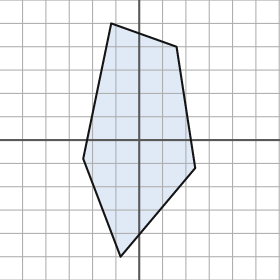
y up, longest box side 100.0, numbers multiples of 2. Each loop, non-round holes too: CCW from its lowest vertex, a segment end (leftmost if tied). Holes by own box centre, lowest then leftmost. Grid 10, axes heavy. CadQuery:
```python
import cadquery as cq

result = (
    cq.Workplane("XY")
    .moveTo(-8.0, -50.0)
    .lineTo(24.0, -12.0)
    .lineTo(16.0, 40.0)
    .lineTo(-12.0, 50.0)
    .lineTo(-24.0, -8.0)
    .close()
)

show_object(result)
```